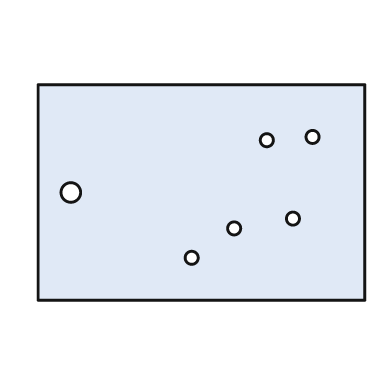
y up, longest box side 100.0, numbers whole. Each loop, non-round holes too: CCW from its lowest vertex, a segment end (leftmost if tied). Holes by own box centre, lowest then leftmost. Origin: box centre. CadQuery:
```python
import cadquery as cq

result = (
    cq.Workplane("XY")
    .moveTo(-50.0, -33.0)
    .lineTo(50.0, -33.0)
    .lineTo(50.0, 33.0)
    .lineTo(-50.0, 33.0)
    .close()
    .moveTo(-3.0, -20.0)
    .circle(2.0)
    .moveTo(10.0, -11.0)
    .circle(2.0)
    .moveTo(28.0, -8.0)
    .circle(2.0)
    .moveTo(-40.0, 0.0)
    .circle(3.0)
    .moveTo(20.0, 16.0)
    .circle(2.0)
    .moveTo(34.0, 17.0)
    .circle(2.0)
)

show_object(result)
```